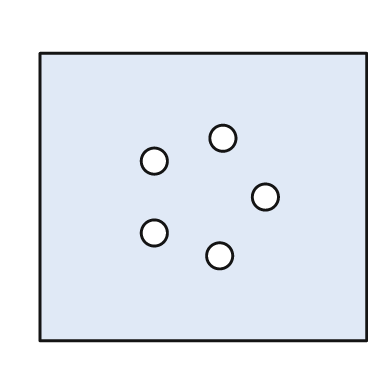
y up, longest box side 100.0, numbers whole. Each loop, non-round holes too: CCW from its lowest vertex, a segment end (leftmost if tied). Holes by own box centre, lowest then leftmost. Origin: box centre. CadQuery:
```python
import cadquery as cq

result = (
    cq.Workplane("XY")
    .moveTo(-50.0, -44.0)
    .lineTo(50.0, -44.0)
    .lineTo(50.0, 44.0)
    .lineTo(-50.0, 44.0)
    .close()
    .moveTo(5.0, -18.0)
    .circle(4.0)
    .moveTo(-15.0, -11.0)
    .circle(4.0)
    .moveTo(19.0, 0.0)
    .circle(4.0)
    .moveTo(-15.0, 11.0)
    .circle(4.0)
    .moveTo(6.0, 18.0)
    .circle(4.0)
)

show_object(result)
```